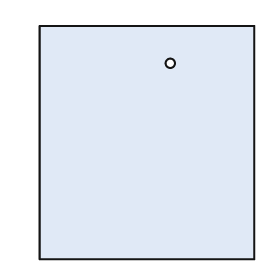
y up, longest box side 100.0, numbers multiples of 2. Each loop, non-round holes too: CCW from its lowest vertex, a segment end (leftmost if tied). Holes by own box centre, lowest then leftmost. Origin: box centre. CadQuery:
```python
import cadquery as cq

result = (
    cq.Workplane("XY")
    .moveTo(-46.0, -50.0)
    .lineTo(46.0, -50.0)
    .lineTo(46.0, 50.0)
    .lineTo(-46.0, 50.0)
    .close()
    .moveTo(10.0, 34.0)
    .circle(2.0)
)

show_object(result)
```